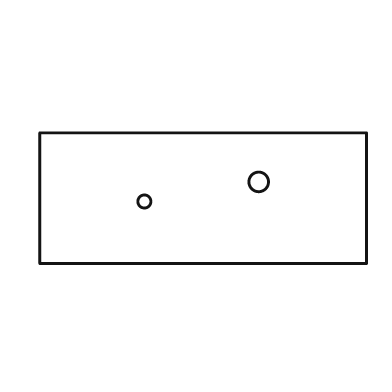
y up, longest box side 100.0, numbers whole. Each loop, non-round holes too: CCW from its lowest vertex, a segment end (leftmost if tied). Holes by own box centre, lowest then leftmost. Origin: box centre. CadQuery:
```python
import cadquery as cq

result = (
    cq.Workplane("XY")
    .moveTo(-50.0, -20.0)
    .lineTo(50.0, -20.0)
    .lineTo(50.0, 20.0)
    .lineTo(-50.0, 20.0)
    .close()
    .moveTo(-18.0, -1.0)
    .circle(2.0)
    .moveTo(17.0, 5.0)
    .circle(3.0)
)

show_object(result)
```